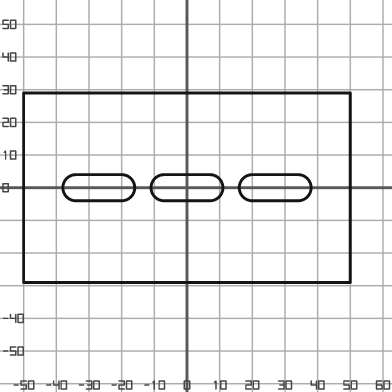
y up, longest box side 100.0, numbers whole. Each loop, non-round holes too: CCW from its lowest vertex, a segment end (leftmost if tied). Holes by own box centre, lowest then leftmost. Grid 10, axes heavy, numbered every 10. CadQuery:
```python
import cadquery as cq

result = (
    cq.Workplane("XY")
    .moveTo(-50.0, -29.0)
    .lineTo(50.0, -29.0)
    .lineTo(50.0, 29.0)
    .lineTo(-50.0, 29.0)
    .close()
    .moveTo(-34.0, -4.0)
    .lineTo(-20.0, -4.0)
    .threePointArc((-16.0, 0.0), (-20.0, 4.0))
    .lineTo(-34.0, 4.0)
    .threePointArc((-38.0, 0.0), (-34.0, -4.0))
    .close()
    .moveTo(-7.0, -4.0)
    .lineTo(7.0, -4.0)
    .threePointArc((11.0, 0.0), (7.0, 4.0))
    .lineTo(-7.0, 4.0)
    .threePointArc((-11.0, 0.0), (-7.0, -4.0))
    .close()
    .moveTo(20.0, -4.0)
    .lineTo(34.0, -4.0)
    .threePointArc((38.0, 0.0), (34.0, 4.0))
    .lineTo(20.0, 4.0)
    .threePointArc((16.0, 0.0), (20.0, -4.0))
    .close()
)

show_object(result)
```